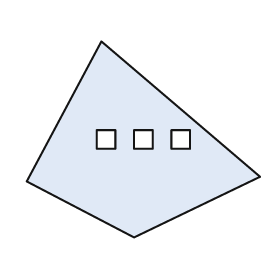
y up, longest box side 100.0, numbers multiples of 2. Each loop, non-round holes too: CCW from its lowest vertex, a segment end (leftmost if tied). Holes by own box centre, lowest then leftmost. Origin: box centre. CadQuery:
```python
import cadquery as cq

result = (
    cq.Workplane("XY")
    .moveTo(-4.0, -42.0)
    .lineTo(50.0, -16.0)
    .lineTo(-18.0, 42.0)
    .lineTo(-50.0, -18.0)
    .close()
    .moveTo(-20.0, -4.0)
    .lineTo(-12.0, -4.0)
    .lineTo(-12.0, 4.0)
    .lineTo(-20.0, 4.0)
    .close()
    .moveTo(-4.0, -4.0)
    .lineTo(4.0, -4.0)
    .lineTo(4.0, 4.0)
    .lineTo(-4.0, 4.0)
    .close()
    .moveTo(12.0, -4.0)
    .lineTo(20.0, -4.0)
    .lineTo(20.0, 4.0)
    .lineTo(12.0, 4.0)
    .close()
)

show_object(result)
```